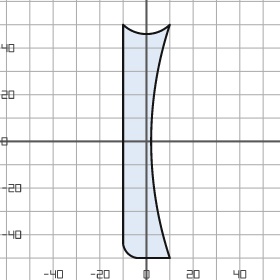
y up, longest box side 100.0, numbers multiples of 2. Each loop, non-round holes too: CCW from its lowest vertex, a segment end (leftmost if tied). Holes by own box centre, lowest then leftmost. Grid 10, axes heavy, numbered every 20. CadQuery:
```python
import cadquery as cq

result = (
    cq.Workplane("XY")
    .moveTo(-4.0, -50.0)
    .lineTo(10.0, -50.0)
    .threePointArc((2.0, 0.0), (10.0, 50.0))
    .threePointArc((0.0, 46.0), (-10.0, 50.0))
    .lineTo(-10.0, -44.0)
    .threePointArc((-8.0, -48.0), (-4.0, -50.0))
    .close()
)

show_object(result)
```